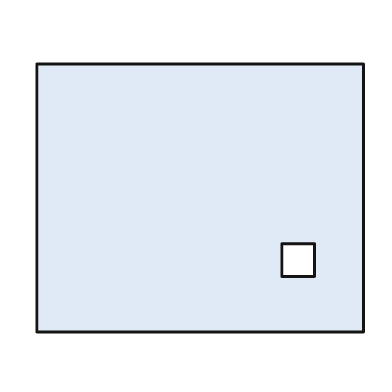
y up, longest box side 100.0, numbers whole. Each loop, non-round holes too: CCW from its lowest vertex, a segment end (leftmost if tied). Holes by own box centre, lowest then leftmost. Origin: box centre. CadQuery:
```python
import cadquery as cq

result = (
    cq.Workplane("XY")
    .moveTo(-50.0, -41.0)
    .lineTo(50.0, -41.0)
    .lineTo(50.0, 41.0)
    .lineTo(-50.0, 41.0)
    .close()
    .moveTo(25.0, -24.0)
    .lineTo(35.0, -24.0)
    .lineTo(35.0, -14.0)
    .lineTo(25.0, -14.0)
    .close()
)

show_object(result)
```